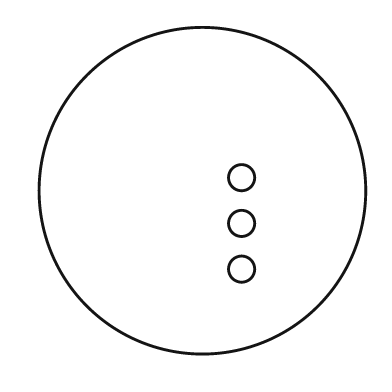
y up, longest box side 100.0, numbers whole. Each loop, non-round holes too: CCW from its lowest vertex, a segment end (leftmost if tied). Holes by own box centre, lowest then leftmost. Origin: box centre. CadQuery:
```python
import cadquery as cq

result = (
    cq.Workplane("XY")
    .moveTo(0.0, 0.0)
    .circle(50.0)
    .moveTo(12.0, -24.0)
    .circle(4.0)
    .moveTo(12.0, -10.0)
    .circle(4.0)
    .moveTo(12.0, 4.0)
    .circle(4.0)
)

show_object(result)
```